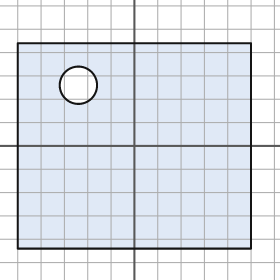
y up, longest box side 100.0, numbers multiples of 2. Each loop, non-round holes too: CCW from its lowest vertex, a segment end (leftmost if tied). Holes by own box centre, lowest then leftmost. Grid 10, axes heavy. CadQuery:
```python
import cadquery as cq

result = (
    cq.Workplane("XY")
    .moveTo(-50.0, -44.0)
    .lineTo(50.0, -44.0)
    .lineTo(50.0, 44.0)
    .lineTo(-50.0, 44.0)
    .close()
    .moveTo(-24.0, 26.0)
    .circle(8.0)
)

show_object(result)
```